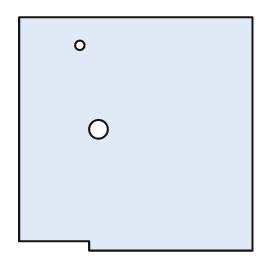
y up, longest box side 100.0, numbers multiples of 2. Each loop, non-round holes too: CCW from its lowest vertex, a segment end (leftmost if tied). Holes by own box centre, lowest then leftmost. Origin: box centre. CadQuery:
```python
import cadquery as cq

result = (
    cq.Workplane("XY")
    .moveTo(-20.0, -50.0)
    .lineTo(50.0, -50.0)
    .lineTo(50.0, 50.0)
    .lineTo(-50.0, 50.0)
    .lineTo(-50.0, -46.0)
    .lineTo(-20.0, -46.0)
    .close()
    .moveTo(-16.0, 2.0)
    .circle(4.0)
    .moveTo(-24.0, 38.0)
    .circle(2.0)
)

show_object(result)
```